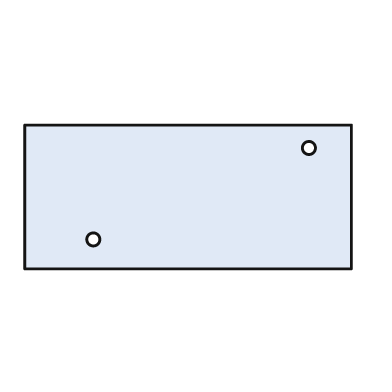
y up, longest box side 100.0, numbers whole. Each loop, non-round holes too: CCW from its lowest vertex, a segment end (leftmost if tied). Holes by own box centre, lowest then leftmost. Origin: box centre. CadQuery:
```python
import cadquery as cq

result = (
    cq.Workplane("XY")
    .moveTo(-50.0, -22.0)
    .lineTo(50.0, -22.0)
    .lineTo(50.0, 22.0)
    .lineTo(-50.0, 22.0)
    .close()
    .moveTo(-29.0, -13.0)
    .circle(2.0)
    .moveTo(37.0, 15.0)
    .circle(2.0)
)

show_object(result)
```